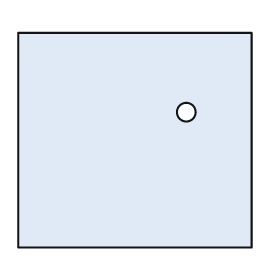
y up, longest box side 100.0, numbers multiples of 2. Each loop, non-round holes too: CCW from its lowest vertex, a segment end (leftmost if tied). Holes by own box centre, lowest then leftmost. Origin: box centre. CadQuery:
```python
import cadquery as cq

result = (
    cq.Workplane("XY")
    .moveTo(-50.0, -46.0)
    .lineTo(50.0, -46.0)
    .lineTo(50.0, 46.0)
    .lineTo(-50.0, 46.0)
    .close()
    .moveTo(22.0, 12.0)
    .circle(4.0)
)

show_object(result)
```